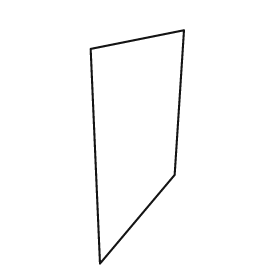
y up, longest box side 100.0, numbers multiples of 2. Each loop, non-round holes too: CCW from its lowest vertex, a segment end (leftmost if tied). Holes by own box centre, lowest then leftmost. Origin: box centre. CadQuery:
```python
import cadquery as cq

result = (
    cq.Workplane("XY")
    .moveTo(-16.0, -50.0)
    .lineTo(16.0, -12.0)
    .lineTo(20.0, 50.0)
    .lineTo(-20.0, 42.0)
    .close()
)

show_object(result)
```